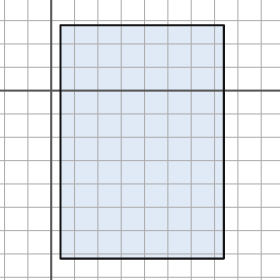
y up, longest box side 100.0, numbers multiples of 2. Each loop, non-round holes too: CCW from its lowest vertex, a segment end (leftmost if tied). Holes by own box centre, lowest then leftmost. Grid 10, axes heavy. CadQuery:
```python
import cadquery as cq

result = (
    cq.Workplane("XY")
    .moveTo(4.0, -72.0)
    .lineTo(74.0, -72.0)
    .lineTo(74.0, 28.0)
    .lineTo(4.0, 28.0)
    .close()
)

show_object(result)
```